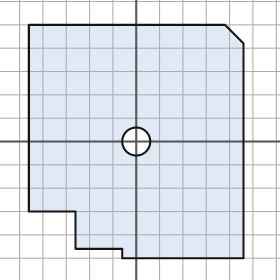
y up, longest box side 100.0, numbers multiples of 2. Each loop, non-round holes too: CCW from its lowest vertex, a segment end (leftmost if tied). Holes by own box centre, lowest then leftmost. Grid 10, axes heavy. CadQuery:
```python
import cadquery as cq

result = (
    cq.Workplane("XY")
    .moveTo(-6.0, -50.0)
    .lineTo(46.0, -50.0)
    .lineTo(46.0, 42.0)
    .lineTo(38.0, 50.0)
    .lineTo(-46.0, 50.0)
    .lineTo(-46.0, -30.0)
    .lineTo(-26.0, -30.0)
    .lineTo(-26.0, -46.0)
    .lineTo(-6.0, -46.0)
    .close()
    .moveTo(0.0, 0.0)
    .circle(6.0)
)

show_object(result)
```